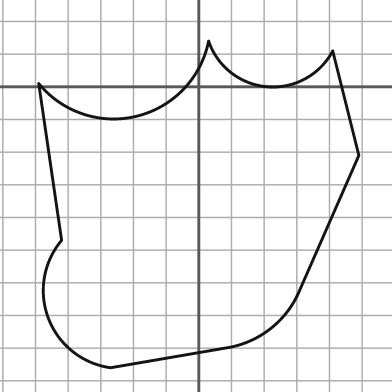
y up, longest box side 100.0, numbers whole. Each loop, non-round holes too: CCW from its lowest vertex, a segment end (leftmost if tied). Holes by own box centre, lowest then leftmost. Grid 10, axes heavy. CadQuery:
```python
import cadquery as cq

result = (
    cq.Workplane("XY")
    .moveTo(-27.0, -86.0)
    .lineTo(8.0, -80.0)
    .threePointArc((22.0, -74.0), (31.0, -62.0))
    .lineTo(49.0, -21.0)
    .lineTo(41.0, 11.0)
    .threePointArc((21.0, 0.0), (3.0, 14.0))
    .threePointArc((-19.0, -9.0), (-49.0, 1.0))
    .lineTo(-42.0, -47.0)
    .threePointArc((-46.0, -71.0), (-27.0, -86.0))
    .close()
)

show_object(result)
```